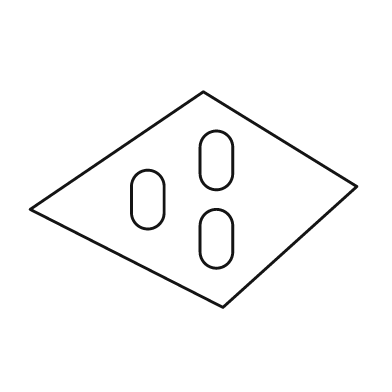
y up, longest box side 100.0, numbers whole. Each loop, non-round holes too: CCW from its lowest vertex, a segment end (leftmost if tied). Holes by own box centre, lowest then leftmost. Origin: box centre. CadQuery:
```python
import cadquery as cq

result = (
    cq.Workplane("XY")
    .moveTo(9.0, -33.0)
    .lineTo(50.0, 4.0)
    .lineTo(3.0, 33.0)
    .lineTo(-50.0, -3.0)
    .close()
    .moveTo(2.0, -16.0)
    .threePointArc((7.0, -21.0), (12.0, -16.0))
    .lineTo(12.0, -8.0)
    .threePointArc((7.0, -3.0), (2.0, -8.0))
    .close()
    .moveTo(-19.0, -4.0)
    .threePointArc((-14.0, -9.0), (-9.0, -4.0))
    .lineTo(-9.0, 4.0)
    .threePointArc((-14.0, 9.0), (-19.0, 4.0))
    .close()
    .moveTo(2.0, 8.0)
    .threePointArc((7.0, 3.0), (12.0, 8.0))
    .lineTo(12.0, 16.0)
    .threePointArc((7.0, 21.0), (2.0, 16.0))
    .close()
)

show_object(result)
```